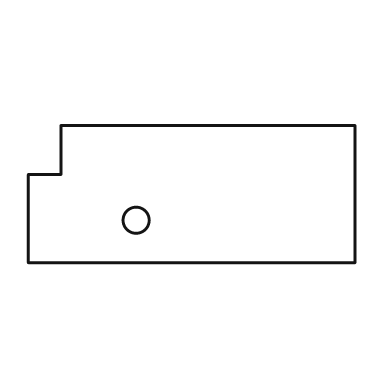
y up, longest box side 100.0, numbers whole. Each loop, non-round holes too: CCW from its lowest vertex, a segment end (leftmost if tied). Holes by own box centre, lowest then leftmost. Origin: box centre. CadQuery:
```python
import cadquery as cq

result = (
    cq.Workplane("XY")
    .moveTo(-50.0, -21.0)
    .lineTo(50.0, -21.0)
    .lineTo(50.0, 21.0)
    .lineTo(-40.0, 21.0)
    .lineTo(-40.0, 6.0)
    .lineTo(-50.0, 6.0)
    .close()
    .moveTo(-17.0, -8.0)
    .circle(4.0)
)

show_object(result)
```